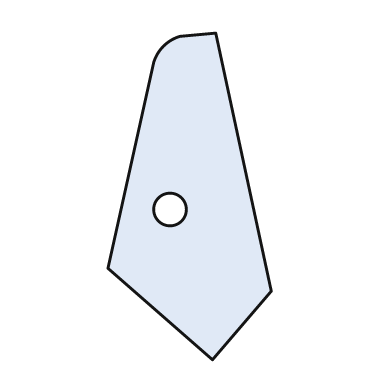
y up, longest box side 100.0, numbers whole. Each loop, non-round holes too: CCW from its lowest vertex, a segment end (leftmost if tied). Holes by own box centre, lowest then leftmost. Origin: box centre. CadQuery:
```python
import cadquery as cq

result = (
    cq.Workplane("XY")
    .moveTo(7.0, -50.0)
    .lineTo(25.0, -29.0)
    .lineTo(8.0, 50.0)
    .lineTo(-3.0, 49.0)
    .threePointArc((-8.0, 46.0), (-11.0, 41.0))
    .lineTo(-25.0, -22.0)
    .close()
    .moveTo(-6.0, -4.0)
    .circle(5.0)
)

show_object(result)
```